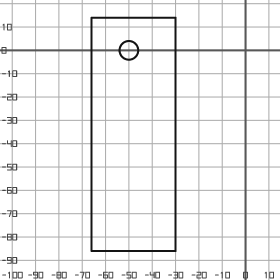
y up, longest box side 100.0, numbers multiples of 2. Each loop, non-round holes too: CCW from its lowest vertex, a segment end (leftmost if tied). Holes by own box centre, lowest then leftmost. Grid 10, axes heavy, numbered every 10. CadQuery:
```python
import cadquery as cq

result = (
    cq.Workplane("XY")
    .moveTo(-66.0, -86.0)
    .lineTo(-30.0, -86.0)
    .lineTo(-30.0, 14.0)
    .lineTo(-66.0, 14.0)
    .close()
    .moveTo(-50.0, 0.0)
    .circle(4.0)
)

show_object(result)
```